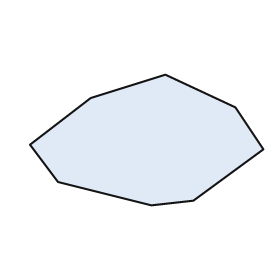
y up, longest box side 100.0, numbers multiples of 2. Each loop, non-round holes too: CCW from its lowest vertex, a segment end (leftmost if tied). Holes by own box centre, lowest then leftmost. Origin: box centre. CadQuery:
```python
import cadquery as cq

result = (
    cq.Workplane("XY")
    .moveTo(2.0, -28.0)
    .lineTo(20.0, -26.0)
    .lineTo(50.0, -4.0)
    .lineTo(38.0, 14.0)
    .lineTo(8.0, 28.0)
    .lineTo(-24.0, 18.0)
    .lineTo(-50.0, -2.0)
    .lineTo(-38.0, -18.0)
    .close()
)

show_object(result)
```